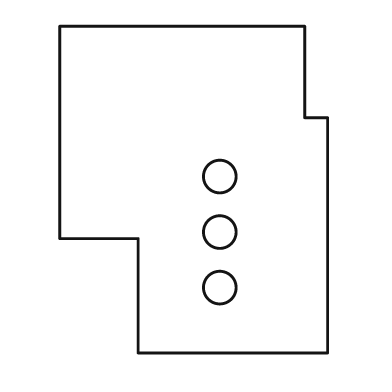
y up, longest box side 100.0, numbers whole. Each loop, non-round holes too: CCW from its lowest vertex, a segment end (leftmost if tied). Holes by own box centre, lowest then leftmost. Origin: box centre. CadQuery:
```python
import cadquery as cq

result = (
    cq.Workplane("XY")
    .moveTo(-17.0, -50.0)
    .lineTo(41.0, -50.0)
    .lineTo(41.0, 22.0)
    .lineTo(34.0, 22.0)
    .lineTo(34.0, 50.0)
    .lineTo(-41.0, 50.0)
    .lineTo(-41.0, -15.0)
    .lineTo(-17.0, -15.0)
    .close()
    .moveTo(8.0, -30.0)
    .circle(5.0)
    .moveTo(8.0, -13.0)
    .circle(5.0)
    .moveTo(8.0, 4.0)
    .circle(5.0)
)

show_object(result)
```